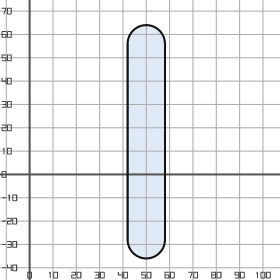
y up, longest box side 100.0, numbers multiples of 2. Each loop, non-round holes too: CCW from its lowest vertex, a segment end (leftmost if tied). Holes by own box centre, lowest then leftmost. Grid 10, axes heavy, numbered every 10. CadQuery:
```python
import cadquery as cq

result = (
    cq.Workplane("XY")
    .moveTo(42.0, -28.0)
    .threePointArc((50.0, -36.0), (58.0, -28.0))
    .lineTo(58.0, 56.0)
    .threePointArc((50.0, 64.0), (42.0, 56.0))
    .close()
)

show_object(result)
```